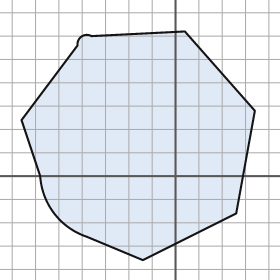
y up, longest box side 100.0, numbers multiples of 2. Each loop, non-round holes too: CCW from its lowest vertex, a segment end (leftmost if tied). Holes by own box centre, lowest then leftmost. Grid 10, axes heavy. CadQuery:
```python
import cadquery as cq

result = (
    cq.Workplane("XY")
    .moveTo(-14.0, -36.0)
    .lineTo(26.0, -16.0)
    .lineTo(34.0, 28.0)
    .lineTo(4.0, 62.0)
    .lineTo(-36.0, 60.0)
    .threePointArc((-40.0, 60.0), (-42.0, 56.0))
    .lineTo(-66.0, 24.0)
    .lineTo(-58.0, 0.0)
    .threePointArc((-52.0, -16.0), (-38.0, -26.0))
    .close()
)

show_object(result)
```